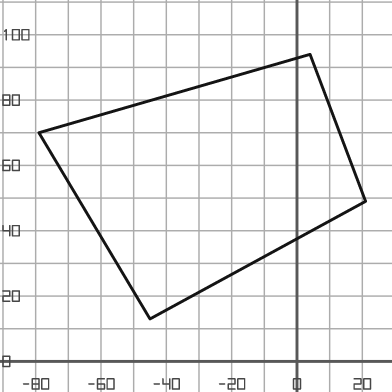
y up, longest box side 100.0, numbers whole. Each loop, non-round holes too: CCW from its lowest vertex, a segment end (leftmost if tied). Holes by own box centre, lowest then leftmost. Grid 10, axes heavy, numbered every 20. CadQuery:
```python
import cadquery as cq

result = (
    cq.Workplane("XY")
    .moveTo(-45.0, 13.0)
    .lineTo(21.0, 49.0)
    .lineTo(4.0, 94.0)
    .lineTo(-79.0, 70.0)
    .close()
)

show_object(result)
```